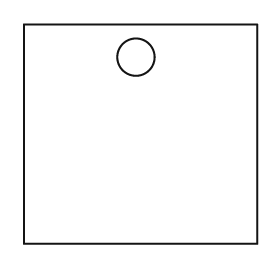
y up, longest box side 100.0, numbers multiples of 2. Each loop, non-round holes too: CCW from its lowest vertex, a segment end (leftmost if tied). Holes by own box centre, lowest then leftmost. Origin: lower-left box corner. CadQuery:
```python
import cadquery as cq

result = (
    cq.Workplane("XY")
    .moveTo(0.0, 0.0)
    .lineTo(100.0, 0.0)
    .lineTo(100.0, 94.0)
    .lineTo(0.0, 94.0)
    .close()
    .moveTo(48.0, 80.0)
    .circle(8.0)
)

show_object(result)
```